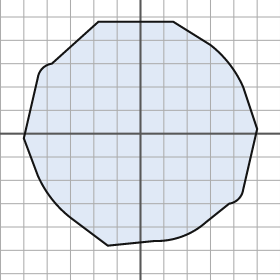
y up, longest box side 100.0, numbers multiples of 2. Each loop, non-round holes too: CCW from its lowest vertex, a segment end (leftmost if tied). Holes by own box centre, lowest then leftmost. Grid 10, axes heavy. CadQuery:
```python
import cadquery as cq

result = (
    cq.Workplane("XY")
    .moveTo(-14.0, -48.0)
    .lineTo(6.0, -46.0)
    .threePointArc((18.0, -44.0), (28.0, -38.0))
    .lineTo(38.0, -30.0)
    .threePointArc((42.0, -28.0), (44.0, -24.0))
    .lineTo(50.0, 2.0)
    .lineTo(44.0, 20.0)
    .threePointArc((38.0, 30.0), (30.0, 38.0))
    .lineTo(14.0, 48.0)
    .lineTo(-18.0, 48.0)
    .lineTo(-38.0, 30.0)
    .threePointArc((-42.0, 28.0), (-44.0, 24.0))
    .lineTo(-50.0, -2.0)
    .lineTo(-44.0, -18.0)
    .threePointArc((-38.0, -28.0), (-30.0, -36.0))
    .close()
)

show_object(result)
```